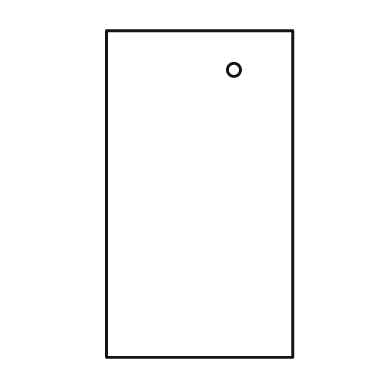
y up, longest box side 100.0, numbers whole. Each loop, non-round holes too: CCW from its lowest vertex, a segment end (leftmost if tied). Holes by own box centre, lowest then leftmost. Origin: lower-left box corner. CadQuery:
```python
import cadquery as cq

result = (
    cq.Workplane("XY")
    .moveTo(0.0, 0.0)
    .lineTo(57.0, 0.0)
    .lineTo(57.0, 100.0)
    .lineTo(0.0, 100.0)
    .close()
    .moveTo(39.0, 88.0)
    .circle(2.0)
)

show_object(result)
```